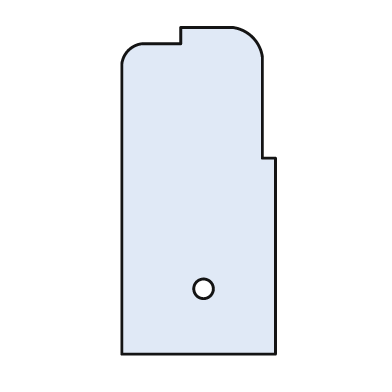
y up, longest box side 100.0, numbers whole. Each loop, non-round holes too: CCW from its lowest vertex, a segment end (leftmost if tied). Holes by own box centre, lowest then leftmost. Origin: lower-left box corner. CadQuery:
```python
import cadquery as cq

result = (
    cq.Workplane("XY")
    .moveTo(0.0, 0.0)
    .lineTo(47.0, 0.0)
    .lineTo(47.0, 60.0)
    .lineTo(43.0, 60.0)
    .lineTo(43.0, 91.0)
    .threePointArc((40.0, 97.0), (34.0, 100.0))
    .lineTo(18.0, 100.0)
    .lineTo(18.0, 95.0)
    .lineTo(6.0, 95.0)
    .threePointArc((2.0, 93.0), (0.0, 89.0))
    .close()
    .moveTo(25.0, 20.0)
    .circle(3.0)
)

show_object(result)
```